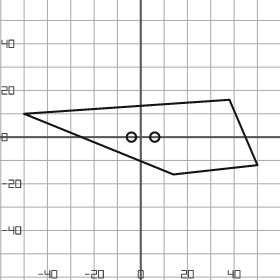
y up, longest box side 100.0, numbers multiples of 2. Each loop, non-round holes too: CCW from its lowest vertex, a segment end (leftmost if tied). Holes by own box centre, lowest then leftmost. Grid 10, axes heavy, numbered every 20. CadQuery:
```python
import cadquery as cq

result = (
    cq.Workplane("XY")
    .moveTo(14.0, -16.0)
    .lineTo(50.0, -12.0)
    .lineTo(38.0, 16.0)
    .lineTo(-50.0, 10.0)
    .close()
    .moveTo(-4.0, 0.0)
    .circle(2.0)
    .moveTo(6.0, 0.0)
    .circle(2.0)
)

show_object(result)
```